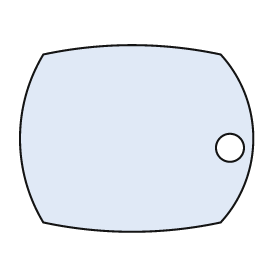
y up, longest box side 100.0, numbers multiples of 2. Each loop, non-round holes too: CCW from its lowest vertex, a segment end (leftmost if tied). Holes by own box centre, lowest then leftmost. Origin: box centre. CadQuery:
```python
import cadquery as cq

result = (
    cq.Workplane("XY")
    .moveTo(-40.0, -36.0)
    .threePointArc((-2.0, -40.0), (36.0, -36.0))
    .threePointArc((50.0, 0.0), (36.0, 36.0))
    .threePointArc((-2.0, 40.0), (-40.0, 36.0))
    .threePointArc((-50.0, 0.0), (-40.0, -36.0))
    .close()
    .moveTo(40.0, -4.0)
    .circle(6.0)
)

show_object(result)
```